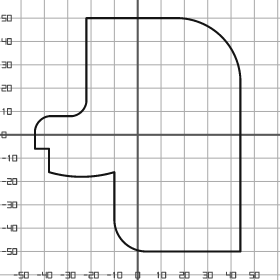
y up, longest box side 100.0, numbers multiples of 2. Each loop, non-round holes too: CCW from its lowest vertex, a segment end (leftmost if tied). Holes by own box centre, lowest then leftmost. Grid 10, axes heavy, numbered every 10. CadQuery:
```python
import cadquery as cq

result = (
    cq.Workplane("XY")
    .moveTo(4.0, -50.0)
    .lineTo(44.0, -50.0)
    .lineTo(44.0, 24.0)
    .threePointArc((36.0, 42.0), (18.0, 50.0))
    .lineTo(-22.0, 50.0)
    .lineTo(-22.0, 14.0)
    .threePointArc((-24.0, 10.0), (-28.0, 8.0))
    .lineTo(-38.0, 8.0)
    .threePointArc((-42.0, 6.0), (-44.0, 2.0))
    .lineTo(-44.0, -6.0)
    .lineTo(-38.0, -6.0)
    .lineTo(-38.0, -16.0)
    .threePointArc((-24.0, -18.0), (-10.0, -16.0))
    .lineTo(-10.0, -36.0)
    .threePointArc((-6.0, -46.0), (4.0, -50.0))
    .close()
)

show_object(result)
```